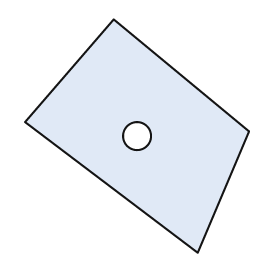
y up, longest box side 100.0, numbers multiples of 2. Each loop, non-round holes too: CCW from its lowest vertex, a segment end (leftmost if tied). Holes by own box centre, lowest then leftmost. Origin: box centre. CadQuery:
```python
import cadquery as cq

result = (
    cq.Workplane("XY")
    .moveTo(26.0, -50.0)
    .lineTo(48.0, 2.0)
    .lineTo(-10.0, 50.0)
    .lineTo(-48.0, 6.0)
    .close()
    .moveTo(0.0, 0.0)
    .circle(6.0)
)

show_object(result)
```